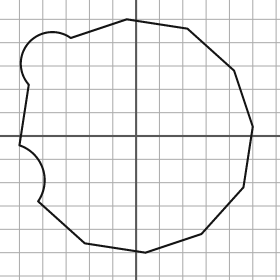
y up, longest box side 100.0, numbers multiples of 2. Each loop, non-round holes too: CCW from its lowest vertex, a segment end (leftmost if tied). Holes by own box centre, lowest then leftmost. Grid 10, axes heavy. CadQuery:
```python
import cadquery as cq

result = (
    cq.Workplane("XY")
    .moveTo(4.0, -50.0)
    .lineTo(28.0, -42.0)
    .lineTo(46.0, -22.0)
    .lineTo(50.0, 4.0)
    .lineTo(42.0, 28.0)
    .lineTo(22.0, 46.0)
    .lineTo(-4.0, 50.0)
    .lineTo(-28.0, 42.0)
    .threePointArc((-46.0, 40.0), (-46.0, 22.0))
    .lineTo(-50.0, -4.0)
    .threePointArc((-40.0, -14.0), (-42.0, -28.0))
    .lineTo(-22.0, -46.0)
    .close()
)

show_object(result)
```